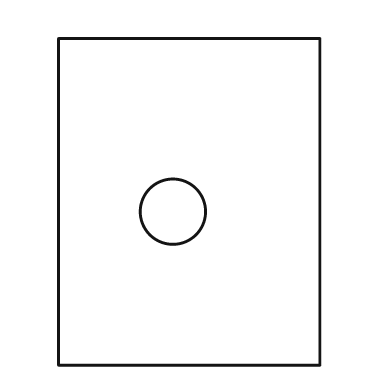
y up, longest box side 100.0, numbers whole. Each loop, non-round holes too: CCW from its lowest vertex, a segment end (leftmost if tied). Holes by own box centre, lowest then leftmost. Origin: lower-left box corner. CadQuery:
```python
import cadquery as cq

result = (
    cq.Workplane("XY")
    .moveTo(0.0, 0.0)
    .lineTo(80.0, 0.0)
    .lineTo(80.0, 100.0)
    .lineTo(0.0, 100.0)
    .close()
    .moveTo(35.0, 47.0)
    .circle(10.0)
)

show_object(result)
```